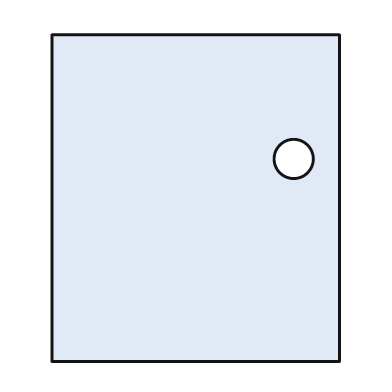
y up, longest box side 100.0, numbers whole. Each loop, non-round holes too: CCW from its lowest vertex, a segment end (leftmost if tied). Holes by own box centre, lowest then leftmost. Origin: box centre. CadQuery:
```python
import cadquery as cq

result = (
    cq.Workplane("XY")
    .moveTo(-44.0, -50.0)
    .lineTo(44.0, -50.0)
    .lineTo(44.0, 50.0)
    .lineTo(-44.0, 50.0)
    .close()
    .moveTo(30.0, 12.0)
    .circle(6.0)
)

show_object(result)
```